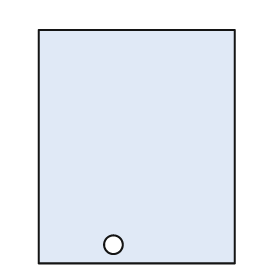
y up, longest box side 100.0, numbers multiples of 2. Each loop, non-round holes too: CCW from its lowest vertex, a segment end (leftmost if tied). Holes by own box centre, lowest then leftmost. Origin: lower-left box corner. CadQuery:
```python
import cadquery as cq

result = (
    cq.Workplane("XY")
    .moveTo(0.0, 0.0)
    .lineTo(84.0, 0.0)
    .lineTo(84.0, 100.0)
    .lineTo(0.0, 100.0)
    .close()
    .moveTo(32.0, 8.0)
    .circle(4.0)
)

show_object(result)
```